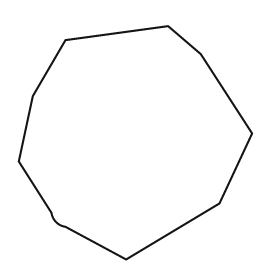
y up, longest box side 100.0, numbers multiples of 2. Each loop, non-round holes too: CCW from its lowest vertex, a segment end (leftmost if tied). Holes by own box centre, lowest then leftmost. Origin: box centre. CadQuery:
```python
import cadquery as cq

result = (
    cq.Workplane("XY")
    .moveTo(-4.0, -50.0)
    .lineTo(36.0, -26.0)
    .lineTo(50.0, 4.0)
    .lineTo(28.0, 38.0)
    .lineTo(14.0, 50.0)
    .lineTo(-30.0, 44.0)
    .lineTo(-44.0, 20.0)
    .lineTo(-50.0, -8.0)
    .lineTo(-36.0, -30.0)
    .threePointArc((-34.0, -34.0), (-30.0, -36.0))
    .close()
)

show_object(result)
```